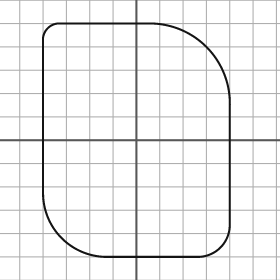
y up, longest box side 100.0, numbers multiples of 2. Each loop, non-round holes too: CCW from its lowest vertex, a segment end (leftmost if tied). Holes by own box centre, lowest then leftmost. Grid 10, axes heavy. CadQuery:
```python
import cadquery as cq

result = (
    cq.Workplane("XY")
    .moveTo(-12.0, -50.0)
    .lineTo(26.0, -50.0)
    .threePointArc((36.0, -46.0), (40.0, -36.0))
    .lineTo(40.0, 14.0)
    .threePointArc((30.0, 40.0), (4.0, 50.0))
    .lineTo(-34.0, 50.0)
    .threePointArc((-38.0, 48.0), (-40.0, 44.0))
    .lineTo(-40.0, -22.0)
    .threePointArc((-32.0, -42.0), (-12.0, -50.0))
    .close()
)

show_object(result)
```